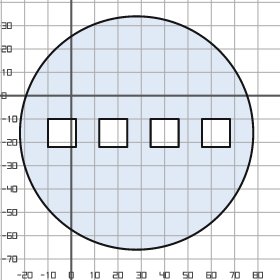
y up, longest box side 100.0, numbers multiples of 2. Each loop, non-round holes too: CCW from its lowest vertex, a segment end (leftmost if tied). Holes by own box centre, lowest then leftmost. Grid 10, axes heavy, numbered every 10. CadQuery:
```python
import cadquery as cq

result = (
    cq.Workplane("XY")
    .moveTo(28.0, -16.0)
    .circle(50.0)
    .moveTo(-10.0, -22.0)
    .lineTo(2.0, -22.0)
    .lineTo(2.0, -10.0)
    .lineTo(-10.0, -10.0)
    .close()
    .moveTo(12.0, -22.0)
    .lineTo(24.0, -22.0)
    .lineTo(24.0, -10.0)
    .lineTo(12.0, -10.0)
    .close()
    .moveTo(34.0, -22.0)
    .lineTo(46.0, -22.0)
    .lineTo(46.0, -10.0)
    .lineTo(34.0, -10.0)
    .close()
    .moveTo(56.0, -22.0)
    .lineTo(68.0, -22.0)
    .lineTo(68.0, -10.0)
    .lineTo(56.0, -10.0)
    .close()
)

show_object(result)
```